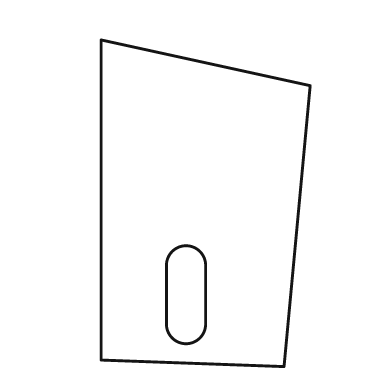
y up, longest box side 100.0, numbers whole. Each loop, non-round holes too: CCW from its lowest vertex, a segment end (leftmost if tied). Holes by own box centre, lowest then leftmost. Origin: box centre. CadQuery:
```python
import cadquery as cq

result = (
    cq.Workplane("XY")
    .moveTo(24.0, -50.0)
    .lineTo(32.0, 36.0)
    .lineTo(-32.0, 50.0)
    .lineTo(-32.0, -48.0)
    .close()
    .moveTo(-12.0, -37.0)
    .threePointArc((-6.0, -43.0), (0.0, -37.0))
    .lineTo(0.0, -19.0)
    .threePointArc((-6.0, -13.0), (-12.0, -19.0))
    .close()
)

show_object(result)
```